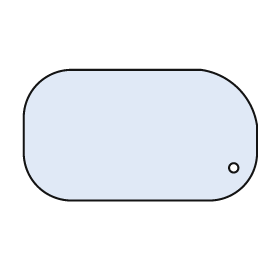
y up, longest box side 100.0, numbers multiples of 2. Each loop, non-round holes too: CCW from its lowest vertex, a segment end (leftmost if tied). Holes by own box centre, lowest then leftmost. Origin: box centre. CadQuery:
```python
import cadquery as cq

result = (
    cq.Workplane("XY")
    .moveTo(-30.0, -28.0)
    .lineTo(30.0, -28.0)
    .threePointArc((44.0, -22.0), (50.0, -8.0))
    .lineTo(50.0, 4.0)
    .threePointArc((42.0, 20.0), (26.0, 28.0))
    .lineTo(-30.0, 28.0)
    .threePointArc((-44.0, 22.0), (-50.0, 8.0))
    .lineTo(-50.0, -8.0)
    .threePointArc((-44.0, -22.0), (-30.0, -28.0))
    .close()
    .moveTo(40.0, -14.0)
    .circle(2.0)
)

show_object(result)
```